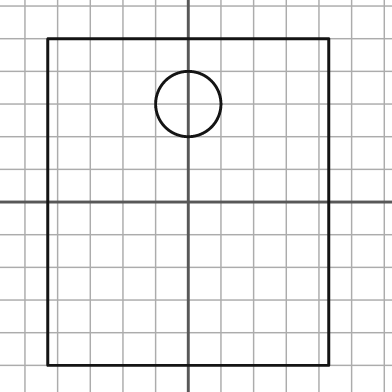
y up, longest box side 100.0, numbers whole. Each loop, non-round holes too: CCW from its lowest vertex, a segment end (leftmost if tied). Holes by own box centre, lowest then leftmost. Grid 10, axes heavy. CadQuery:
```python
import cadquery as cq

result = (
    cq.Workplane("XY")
    .moveTo(-43.0, -50.0)
    .lineTo(43.0, -50.0)
    .lineTo(43.0, 50.0)
    .lineTo(-43.0, 50.0)
    .close()
    .moveTo(0.0, 30.0)
    .circle(10.0)
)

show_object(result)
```